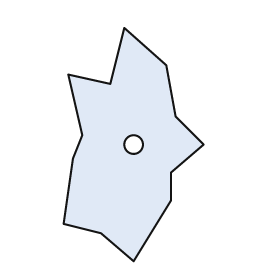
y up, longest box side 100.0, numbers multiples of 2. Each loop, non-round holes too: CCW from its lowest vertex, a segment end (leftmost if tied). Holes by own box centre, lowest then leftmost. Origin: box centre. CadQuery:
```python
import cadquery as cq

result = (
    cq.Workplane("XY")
    .moveTo(0.0, -50.0)
    .lineTo(16.0, -24.0)
    .lineTo(16.0, -12.0)
    .lineTo(30.0, 0.0)
    .lineTo(18.0, 12.0)
    .lineTo(14.0, 34.0)
    .lineTo(-4.0, 50.0)
    .lineTo(-10.0, 26.0)
    .lineTo(-28.0, 30.0)
    .lineTo(-22.0, 4.0)
    .lineTo(-26.0, -6.0)
    .lineTo(-30.0, -34.0)
    .lineTo(-14.0, -38.0)
    .close()
    .moveTo(0.0, 0.0)
    .circle(4.0)
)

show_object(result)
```